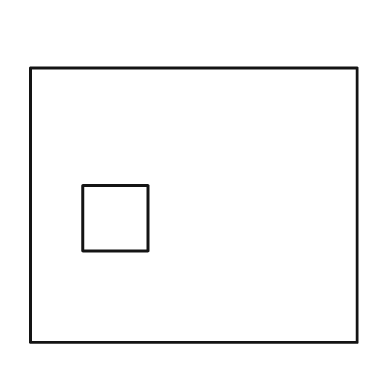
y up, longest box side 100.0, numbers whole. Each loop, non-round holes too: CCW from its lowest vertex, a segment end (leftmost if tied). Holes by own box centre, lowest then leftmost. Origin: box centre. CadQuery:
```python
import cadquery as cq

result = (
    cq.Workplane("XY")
    .moveTo(-50.0, -42.0)
    .lineTo(50.0, -42.0)
    .lineTo(50.0, 42.0)
    .lineTo(-50.0, 42.0)
    .close()
    .moveTo(-34.0, -14.0)
    .lineTo(-14.0, -14.0)
    .lineTo(-14.0, 6.0)
    .lineTo(-34.0, 6.0)
    .close()
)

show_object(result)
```